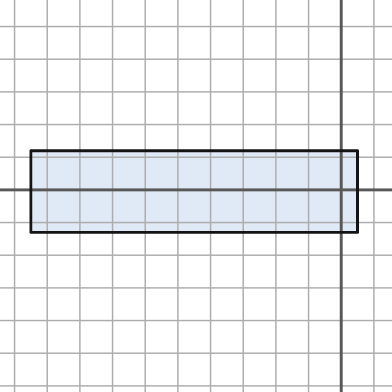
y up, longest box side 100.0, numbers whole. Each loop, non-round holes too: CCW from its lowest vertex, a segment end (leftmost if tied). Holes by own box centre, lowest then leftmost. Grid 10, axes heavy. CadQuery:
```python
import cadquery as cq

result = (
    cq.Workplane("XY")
    .moveTo(-95.0, -13.0)
    .lineTo(5.0, -13.0)
    .lineTo(5.0, 12.0)
    .lineTo(-95.0, 12.0)
    .close()
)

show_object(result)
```